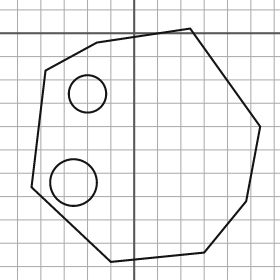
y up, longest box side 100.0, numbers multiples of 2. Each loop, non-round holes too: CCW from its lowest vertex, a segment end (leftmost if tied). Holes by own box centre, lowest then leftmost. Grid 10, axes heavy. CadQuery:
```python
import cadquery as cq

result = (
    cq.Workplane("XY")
    .moveTo(-10.0, -98.0)
    .lineTo(30.0, -94.0)
    .lineTo(48.0, -72.0)
    .lineTo(54.0, -40.0)
    .lineTo(24.0, 2.0)
    .lineTo(-16.0, -4.0)
    .lineTo(-38.0, -16.0)
    .lineTo(-44.0, -66.0)
    .close()
    .moveTo(-26.0, -64.0)
    .circle(10.0)
    .moveTo(-20.0, -26.0)
    .circle(8.0)
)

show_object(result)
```